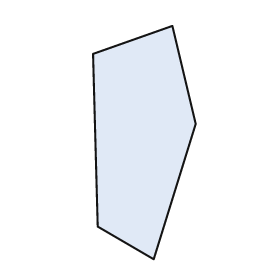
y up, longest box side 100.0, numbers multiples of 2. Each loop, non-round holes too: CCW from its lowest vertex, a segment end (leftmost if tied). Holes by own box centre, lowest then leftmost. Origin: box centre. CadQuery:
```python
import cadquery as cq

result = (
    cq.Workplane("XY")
    .moveTo(4.0, -50.0)
    .lineTo(22.0, 8.0)
    .lineTo(12.0, 50.0)
    .lineTo(-22.0, 38.0)
    .lineTo(-20.0, -36.0)
    .close()
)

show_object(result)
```